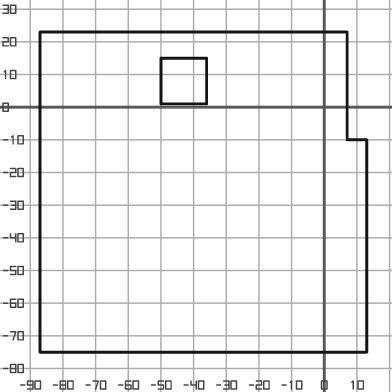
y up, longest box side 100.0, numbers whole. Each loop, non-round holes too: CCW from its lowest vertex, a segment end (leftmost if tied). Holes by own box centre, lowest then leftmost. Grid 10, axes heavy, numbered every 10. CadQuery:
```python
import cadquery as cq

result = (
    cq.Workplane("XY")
    .moveTo(-87.0, -75.0)
    .lineTo(13.0, -75.0)
    .lineTo(13.0, -10.0)
    .lineTo(7.0, -10.0)
    .lineTo(7.0, 23.0)
    .lineTo(-87.0, 23.0)
    .close()
    .moveTo(-50.0, 1.0)
    .lineTo(-36.0, 1.0)
    .lineTo(-36.0, 15.0)
    .lineTo(-50.0, 15.0)
    .close()
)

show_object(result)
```